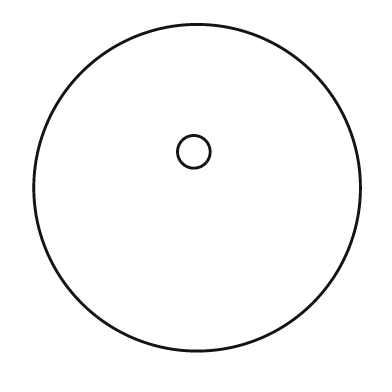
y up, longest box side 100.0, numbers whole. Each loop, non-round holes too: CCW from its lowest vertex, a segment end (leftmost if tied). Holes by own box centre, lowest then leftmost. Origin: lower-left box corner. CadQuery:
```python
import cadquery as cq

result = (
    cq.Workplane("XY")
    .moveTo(50.0, 50.0)
    .circle(50.0)
    .moveTo(49.0, 61.0)
    .circle(5.0)
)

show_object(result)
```